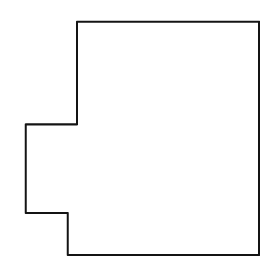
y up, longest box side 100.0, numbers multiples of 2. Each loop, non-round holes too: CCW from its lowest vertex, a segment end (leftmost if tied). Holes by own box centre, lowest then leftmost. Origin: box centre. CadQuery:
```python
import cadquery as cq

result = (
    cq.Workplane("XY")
    .moveTo(-32.0, -50.0)
    .lineTo(50.0, -50.0)
    .lineTo(50.0, 50.0)
    .lineTo(-28.0, 50.0)
    .lineTo(-28.0, 6.0)
    .lineTo(-50.0, 6.0)
    .lineTo(-50.0, -32.0)
    .lineTo(-32.0, -32.0)
    .close()
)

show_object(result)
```